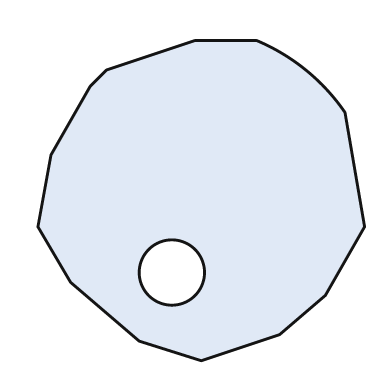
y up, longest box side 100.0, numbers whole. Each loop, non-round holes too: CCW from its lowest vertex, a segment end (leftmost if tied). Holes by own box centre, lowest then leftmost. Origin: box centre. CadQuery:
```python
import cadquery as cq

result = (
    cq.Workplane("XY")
    .moveTo(0.0, -49.0)
    .lineTo(24.0, -41.0)
    .lineTo(38.0, -29.0)
    .lineTo(50.0, -8.0)
    .lineTo(44.0, 27.0)
    .threePointArc((32.0, 40.0), (17.0, 49.0))
    .lineTo(-2.0, 49.0)
    .lineTo(-29.0, 40.0)
    .lineTo(-34.0, 35.0)
    .lineTo(-46.0, 14.0)
    .lineTo(-50.0, -8.0)
    .lineTo(-40.0, -25.0)
    .lineTo(-19.0, -43.0)
    .close()
    .moveTo(-9.0, -22.0)
    .circle(10.0)
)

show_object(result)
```